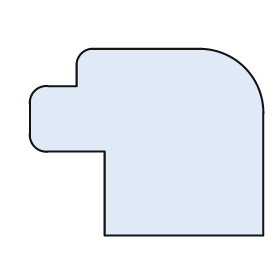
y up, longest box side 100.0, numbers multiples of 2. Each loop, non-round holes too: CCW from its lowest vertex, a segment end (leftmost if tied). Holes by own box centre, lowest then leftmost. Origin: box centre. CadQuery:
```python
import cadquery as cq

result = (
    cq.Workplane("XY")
    .moveTo(-18.0, -40.0)
    .lineTo(50.0, -40.0)
    .lineTo(50.0, 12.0)
    .threePointArc((42.0, 32.0), (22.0, 40.0))
    .lineTo(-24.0, 40.0)
    .threePointArc((-28.0, 38.0), (-30.0, 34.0))
    .lineTo(-30.0, 24.0)
    .lineTo(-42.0, 24.0)
    .threePointArc((-48.0, 22.0), (-50.0, 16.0))
    .lineTo(-50.0, 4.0)
    .threePointArc((-48.0, -2.0), (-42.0, -4.0))
    .lineTo(-18.0, -4.0)
    .close()
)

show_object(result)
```